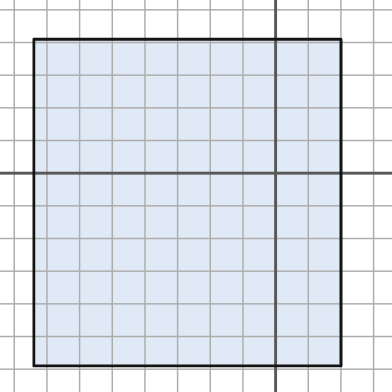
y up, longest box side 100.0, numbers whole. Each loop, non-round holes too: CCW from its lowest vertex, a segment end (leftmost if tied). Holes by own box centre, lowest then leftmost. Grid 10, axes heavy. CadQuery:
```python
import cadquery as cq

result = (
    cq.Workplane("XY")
    .moveTo(-74.0, -59.0)
    .lineTo(20.0, -59.0)
    .lineTo(20.0, 41.0)
    .lineTo(-74.0, 41.0)
    .close()
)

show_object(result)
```